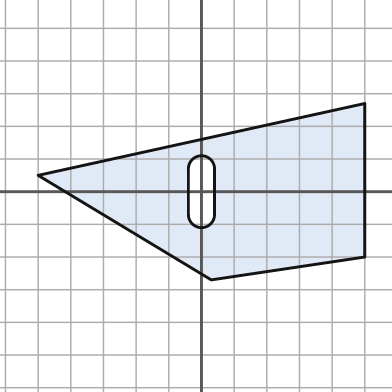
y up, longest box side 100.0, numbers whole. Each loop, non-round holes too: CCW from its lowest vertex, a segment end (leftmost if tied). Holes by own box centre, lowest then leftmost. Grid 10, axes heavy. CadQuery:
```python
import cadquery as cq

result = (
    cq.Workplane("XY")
    .moveTo(3.0, -27.0)
    .lineTo(50.0, -20.0)
    .lineTo(50.0, 27.0)
    .lineTo(-50.0, 5.0)
    .close()
    .moveTo(-4.0, -7.0)
    .threePointArc((0.0, -11.0), (4.0, -7.0))
    .lineTo(4.0, 7.0)
    .threePointArc((0.0, 11.0), (-4.0, 7.0))
    .close()
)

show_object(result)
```